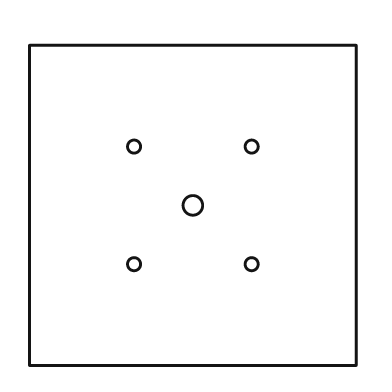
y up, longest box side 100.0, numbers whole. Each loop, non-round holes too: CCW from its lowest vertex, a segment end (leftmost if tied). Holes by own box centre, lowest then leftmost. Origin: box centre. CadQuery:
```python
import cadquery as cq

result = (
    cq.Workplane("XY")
    .moveTo(-50.0, -49.0)
    .lineTo(50.0, -49.0)
    .lineTo(50.0, 49.0)
    .lineTo(-50.0, 49.0)
    .close()
    .moveTo(-18.0, -18.0)
    .circle(2.0)
    .moveTo(18.0, -18.0)
    .circle(2.0)
    .moveTo(0.0, 0.0)
    .circle(3.0)
    .moveTo(-18.0, 18.0)
    .circle(2.0)
    .moveTo(18.0, 18.0)
    .circle(2.0)
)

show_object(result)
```